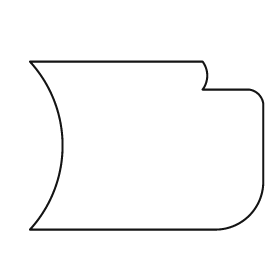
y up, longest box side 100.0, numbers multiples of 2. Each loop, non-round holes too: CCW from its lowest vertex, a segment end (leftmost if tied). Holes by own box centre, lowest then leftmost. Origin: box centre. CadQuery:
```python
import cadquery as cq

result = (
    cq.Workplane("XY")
    .moveTo(-50.0, -36.0)
    .lineTo(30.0, -36.0)
    .threePointArc((44.0, -30.0), (50.0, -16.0))
    .lineTo(50.0, 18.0)
    .threePointArc((48.0, 22.0), (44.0, 24.0))
    .lineTo(24.0, 24.0)
    .threePointArc((26.0, 30.0), (24.0, 36.0))
    .lineTo(-50.0, 36.0)
    .threePointArc((-36.0, 0.0), (-50.0, -36.0))
    .close()
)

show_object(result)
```